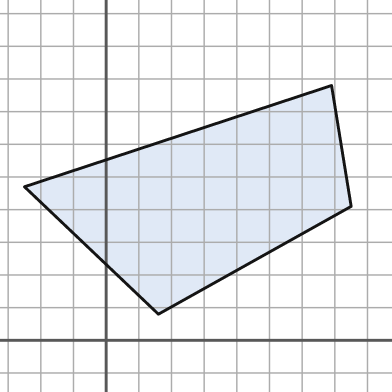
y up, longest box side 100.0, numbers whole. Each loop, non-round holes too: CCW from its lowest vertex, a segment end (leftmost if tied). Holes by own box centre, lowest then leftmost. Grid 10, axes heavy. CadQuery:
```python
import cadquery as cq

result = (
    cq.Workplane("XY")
    .moveTo(16.0, 8.0)
    .lineTo(75.0, 41.0)
    .lineTo(69.0, 78.0)
    .lineTo(-25.0, 47.0)
    .close()
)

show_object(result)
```